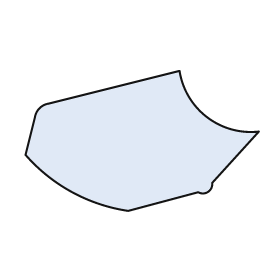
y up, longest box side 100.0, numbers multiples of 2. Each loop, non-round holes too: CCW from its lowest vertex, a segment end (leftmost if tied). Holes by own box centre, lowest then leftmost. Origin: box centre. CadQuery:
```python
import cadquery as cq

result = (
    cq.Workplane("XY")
    .moveTo(-6.0, -30.0)
    .lineTo(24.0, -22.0)
    .threePointArc((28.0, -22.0), (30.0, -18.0))
    .lineTo(50.0, 4.0)
    .threePointArc((28.0, 10.0), (16.0, 30.0))
    .lineTo(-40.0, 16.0)
    .threePointArc((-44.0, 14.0), (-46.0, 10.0))
    .lineTo(-50.0, -6.0)
    .threePointArc((-30.0, -22.0), (-6.0, -30.0))
    .close()
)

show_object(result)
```